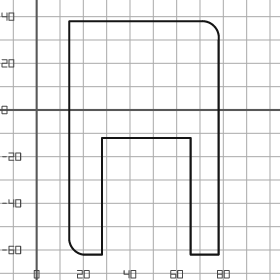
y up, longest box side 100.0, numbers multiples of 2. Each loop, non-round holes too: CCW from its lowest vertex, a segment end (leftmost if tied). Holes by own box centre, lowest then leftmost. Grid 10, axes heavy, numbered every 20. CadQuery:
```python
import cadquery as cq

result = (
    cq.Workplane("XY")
    .moveTo(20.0, -62.0)
    .lineTo(28.0, -62.0)
    .lineTo(28.0, -12.0)
    .lineTo(66.0, -12.0)
    .lineTo(66.0, -62.0)
    .lineTo(78.0, -62.0)
    .lineTo(78.0, 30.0)
    .threePointArc((76.0, 36.0), (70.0, 38.0))
    .lineTo(14.0, 38.0)
    .lineTo(14.0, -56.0)
    .threePointArc((16.0, -60.0), (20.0, -62.0))
    .close()
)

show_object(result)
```